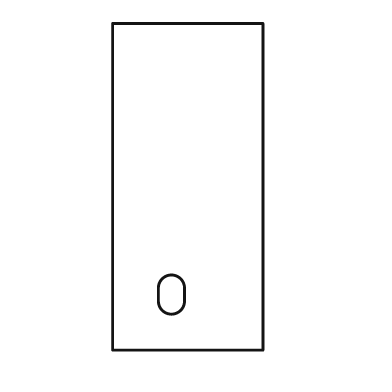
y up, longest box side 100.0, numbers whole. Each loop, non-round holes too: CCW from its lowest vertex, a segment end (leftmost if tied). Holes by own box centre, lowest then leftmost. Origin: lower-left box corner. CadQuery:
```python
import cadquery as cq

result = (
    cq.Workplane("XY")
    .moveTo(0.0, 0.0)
    .lineTo(46.0, 0.0)
    .lineTo(46.0, 100.0)
    .lineTo(0.0, 100.0)
    .close()
    .moveTo(14.0, 15.0)
    .threePointArc((18.0, 11.0), (22.0, 15.0))
    .lineTo(22.0, 19.0)
    .threePointArc((18.0, 23.0), (14.0, 19.0))
    .close()
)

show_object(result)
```